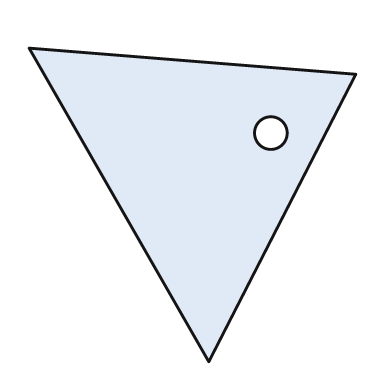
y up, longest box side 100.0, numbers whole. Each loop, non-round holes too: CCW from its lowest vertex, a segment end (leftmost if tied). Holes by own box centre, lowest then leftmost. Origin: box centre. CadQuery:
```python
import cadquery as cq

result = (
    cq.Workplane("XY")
    .moveTo(5.0, -48.0)
    .lineTo(50.0, 40.0)
    .lineTo(-50.0, 48.0)
    .close()
    .moveTo(24.0, 22.0)
    .circle(5.0)
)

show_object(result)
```